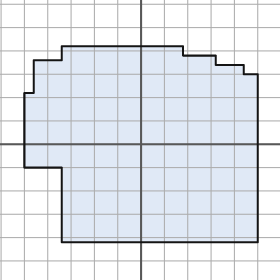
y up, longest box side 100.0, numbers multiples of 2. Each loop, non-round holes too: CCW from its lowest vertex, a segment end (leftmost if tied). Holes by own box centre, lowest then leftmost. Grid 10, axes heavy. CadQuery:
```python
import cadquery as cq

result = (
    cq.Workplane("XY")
    .moveTo(-34.0, -42.0)
    .lineTo(50.0, -42.0)
    .lineTo(50.0, 30.0)
    .lineTo(44.0, 30.0)
    .lineTo(44.0, 34.0)
    .lineTo(32.0, 34.0)
    .lineTo(32.0, 38.0)
    .lineTo(18.0, 38.0)
    .lineTo(18.0, 42.0)
    .lineTo(-34.0, 42.0)
    .lineTo(-34.0, 36.0)
    .lineTo(-46.0, 36.0)
    .lineTo(-46.0, 22.0)
    .lineTo(-50.0, 22.0)
    .lineTo(-50.0, -10.0)
    .lineTo(-34.0, -10.0)
    .close()
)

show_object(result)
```